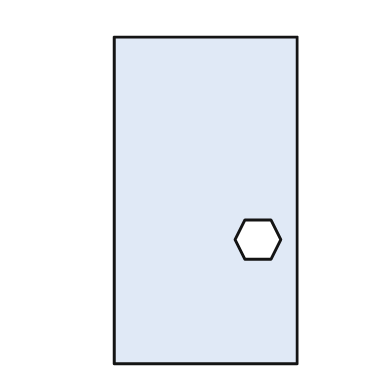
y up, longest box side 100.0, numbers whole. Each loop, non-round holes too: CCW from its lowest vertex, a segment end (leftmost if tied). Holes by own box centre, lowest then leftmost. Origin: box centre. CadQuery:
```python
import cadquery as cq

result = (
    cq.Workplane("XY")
    .moveTo(-28.0, -50.0)
    .lineTo(28.0, -50.0)
    .lineTo(28.0, 50.0)
    .lineTo(-28.0, 50.0)
    .close()
    .moveTo(12.0, -18.0)
    .lineTo(20.0, -18.0)
    .lineTo(23.0, -12.0)
    .lineTo(20.0, -6.0)
    .lineTo(12.0, -6.0)
    .lineTo(9.0, -12.0)
    .close()
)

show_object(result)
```